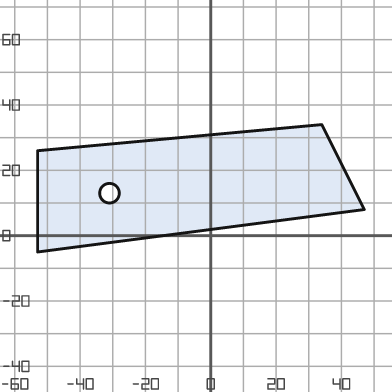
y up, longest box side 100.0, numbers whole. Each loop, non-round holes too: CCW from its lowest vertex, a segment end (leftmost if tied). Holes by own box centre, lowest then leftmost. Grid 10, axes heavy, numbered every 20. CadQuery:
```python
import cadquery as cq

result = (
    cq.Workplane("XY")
    .moveTo(-53.0, -5.0)
    .lineTo(47.0, 8.0)
    .lineTo(34.0, 34.0)
    .lineTo(-53.0, 26.0)
    .close()
    .moveTo(-31.0, 13.0)
    .circle(3.0)
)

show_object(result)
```